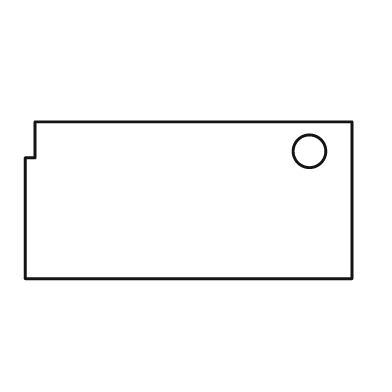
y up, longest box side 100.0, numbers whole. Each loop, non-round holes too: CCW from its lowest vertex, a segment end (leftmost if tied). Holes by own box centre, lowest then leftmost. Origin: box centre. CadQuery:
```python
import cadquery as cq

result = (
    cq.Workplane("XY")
    .moveTo(-50.0, -24.0)
    .lineTo(50.0, -24.0)
    .lineTo(50.0, 24.0)
    .lineTo(-47.0, 24.0)
    .lineTo(-47.0, 13.0)
    .lineTo(-50.0, 13.0)
    .close()
    .moveTo(37.0, 15.0)
    .circle(5.0)
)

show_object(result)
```